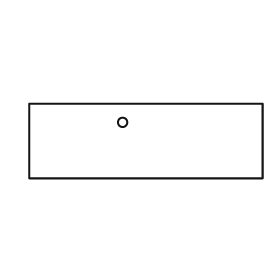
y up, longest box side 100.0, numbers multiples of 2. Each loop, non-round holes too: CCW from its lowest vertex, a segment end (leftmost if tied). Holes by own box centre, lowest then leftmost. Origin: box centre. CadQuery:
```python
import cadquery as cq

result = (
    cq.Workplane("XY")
    .moveTo(-50.0, -16.0)
    .lineTo(50.0, -16.0)
    .lineTo(50.0, 16.0)
    .lineTo(-50.0, 16.0)
    .close()
    .moveTo(-10.0, 8.0)
    .circle(2.0)
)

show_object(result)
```